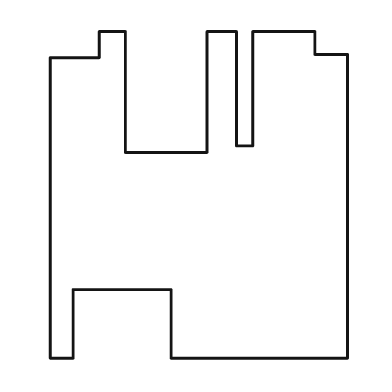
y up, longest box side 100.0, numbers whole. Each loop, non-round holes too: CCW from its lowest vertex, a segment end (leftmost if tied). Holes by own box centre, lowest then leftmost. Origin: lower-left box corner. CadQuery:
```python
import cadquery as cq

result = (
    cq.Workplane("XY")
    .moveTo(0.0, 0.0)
    .lineTo(7.0, 0.0)
    .lineTo(7.0, 21.0)
    .lineTo(37.0, 21.0)
    .lineTo(37.0, 0.0)
    .lineTo(91.0, 0.0)
    .lineTo(91.0, 93.0)
    .lineTo(81.0, 93.0)
    .lineTo(81.0, 100.0)
    .lineTo(62.0, 100.0)
    .lineTo(62.0, 65.0)
    .lineTo(57.0, 65.0)
    .lineTo(57.0, 100.0)
    .lineTo(48.0, 100.0)
    .lineTo(48.0, 63.0)
    .lineTo(23.0, 63.0)
    .lineTo(23.0, 100.0)
    .lineTo(15.0, 100.0)
    .lineTo(15.0, 92.0)
    .lineTo(0.0, 92.0)
    .close()
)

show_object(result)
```